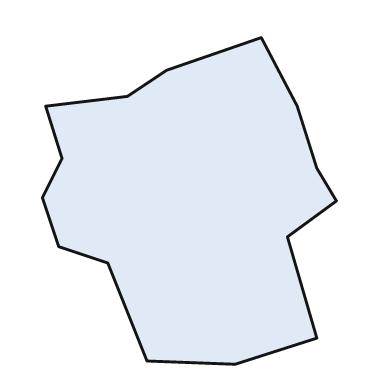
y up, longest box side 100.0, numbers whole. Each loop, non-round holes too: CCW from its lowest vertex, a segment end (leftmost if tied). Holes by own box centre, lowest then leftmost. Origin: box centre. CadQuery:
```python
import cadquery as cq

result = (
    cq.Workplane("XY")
    .moveTo(14.0, -50.0)
    .lineTo(39.0, -42.0)
    .lineTo(30.0, -11.0)
    .lineTo(45.0, 0.0)
    .lineTo(39.0, 10.0)
    .lineTo(33.0, 29.0)
    .lineTo(22.0, 50.0)
    .lineTo(-7.0, 40.0)
    .lineTo(-19.0, 32.0)
    .lineTo(-44.0, 29.0)
    .lineTo(-39.0, 13.0)
    .lineTo(-45.0, 1.0)
    .lineTo(-40.0, -14.0)
    .lineTo(-25.0, -19.0)
    .lineTo(-13.0, -49.0)
    .close()
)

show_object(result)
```